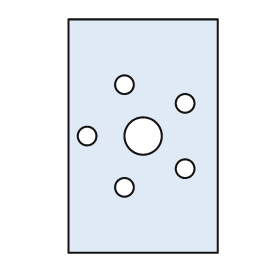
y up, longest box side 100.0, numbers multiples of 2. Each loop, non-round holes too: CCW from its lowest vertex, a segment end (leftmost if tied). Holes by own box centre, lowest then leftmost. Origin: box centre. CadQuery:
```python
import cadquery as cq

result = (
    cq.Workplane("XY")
    .moveTo(-32.0, -50.0)
    .lineTo(32.0, -50.0)
    .lineTo(32.0, 50.0)
    .lineTo(-32.0, 50.0)
    .close()
    .moveTo(-8.0, -22.0)
    .circle(4.0)
    .moveTo(18.0, -14.0)
    .circle(4.0)
    .moveTo(-24.0, 0.0)
    .circle(4.0)
    .moveTo(0.0, 0.0)
    .circle(8.0)
    .moveTo(18.0, 14.0)
    .circle(4.0)
    .moveTo(-8.0, 22.0)
    .circle(4.0)
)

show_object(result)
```